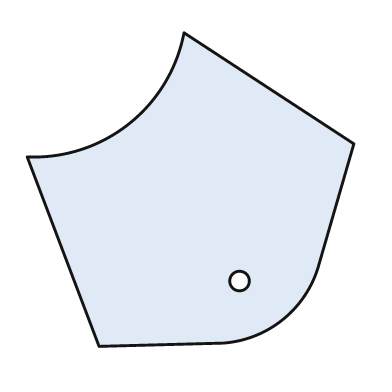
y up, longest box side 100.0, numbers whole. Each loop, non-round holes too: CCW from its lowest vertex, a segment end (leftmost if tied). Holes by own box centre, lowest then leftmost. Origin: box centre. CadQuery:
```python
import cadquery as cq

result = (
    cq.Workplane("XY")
    .moveTo(-28.0, -48.0)
    .lineTo(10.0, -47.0)
    .threePointArc((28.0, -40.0), (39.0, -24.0))
    .lineTo(50.0, 14.0)
    .lineTo(-2.0, 48.0)
    .threePointArc((-19.0, 20.0), (-50.0, 10.0))
    .close()
    .moveTo(15.0, -28.0)
    .circle(3.0)
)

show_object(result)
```